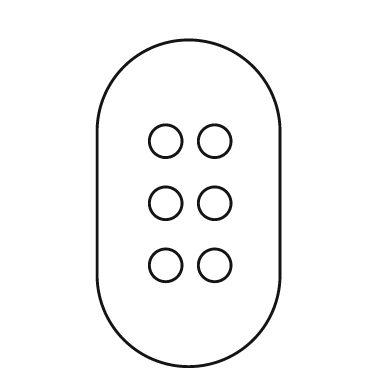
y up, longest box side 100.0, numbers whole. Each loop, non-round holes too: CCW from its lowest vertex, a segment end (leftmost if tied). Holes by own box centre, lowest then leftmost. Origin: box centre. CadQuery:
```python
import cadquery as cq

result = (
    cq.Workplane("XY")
    .moveTo(-28.0, -22.0)
    .threePointArc((0.0, -50.0), (28.0, -22.0))
    .lineTo(28.0, 22.0)
    .threePointArc((0.0, 50.0), (-28.0, 22.0))
    .close()
    .moveTo(-7.0, -19.0)
    .circle(5.0)
    .moveTo(8.0, -19.0)
    .circle(5.0)
    .moveTo(-7.0, 0.0)
    .circle(5.0)
    .moveTo(8.0, 0.0)
    .circle(5.0)
    .moveTo(-7.0, 19.0)
    .circle(5.0)
    .moveTo(8.0, 19.0)
    .circle(5.0)
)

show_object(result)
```